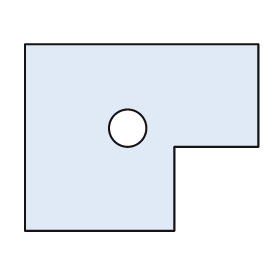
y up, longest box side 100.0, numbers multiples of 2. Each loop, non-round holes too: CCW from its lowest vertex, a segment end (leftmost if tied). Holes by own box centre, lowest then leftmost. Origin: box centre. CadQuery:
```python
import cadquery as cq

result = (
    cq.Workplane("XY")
    .moveTo(-50.0, -40.0)
    .lineTo(14.0, -40.0)
    .lineTo(14.0, -4.0)
    .lineTo(50.0, -4.0)
    .lineTo(50.0, 40.0)
    .lineTo(-50.0, 40.0)
    .close()
    .moveTo(-6.0, 4.0)
    .circle(8.0)
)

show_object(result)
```